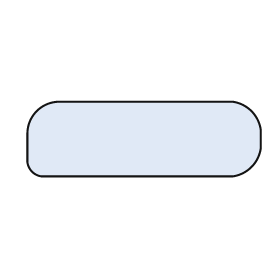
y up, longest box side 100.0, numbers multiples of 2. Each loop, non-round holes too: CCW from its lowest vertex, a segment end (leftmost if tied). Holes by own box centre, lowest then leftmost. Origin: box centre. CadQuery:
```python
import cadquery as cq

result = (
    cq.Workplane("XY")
    .moveTo(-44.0, -16.0)
    .lineTo(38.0, -16.0)
    .threePointArc((46.0, -12.0), (50.0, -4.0))
    .lineTo(50.0, 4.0)
    .threePointArc((46.0, 12.0), (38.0, 16.0))
    .lineTo(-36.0, 16.0)
    .threePointArc((-46.0, 12.0), (-50.0, 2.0))
    .lineTo(-50.0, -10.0)
    .threePointArc((-48.0, -14.0), (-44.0, -16.0))
    .close()
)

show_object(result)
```